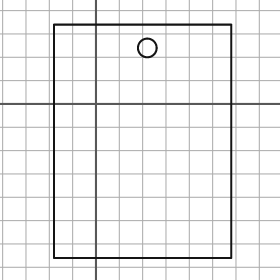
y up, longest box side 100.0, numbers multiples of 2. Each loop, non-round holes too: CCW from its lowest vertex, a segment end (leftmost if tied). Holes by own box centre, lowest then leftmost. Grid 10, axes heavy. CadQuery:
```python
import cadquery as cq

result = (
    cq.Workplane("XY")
    .moveTo(-18.0, -66.0)
    .lineTo(58.0, -66.0)
    .lineTo(58.0, 34.0)
    .lineTo(-18.0, 34.0)
    .close()
    .moveTo(22.0, 24.0)
    .circle(4.0)
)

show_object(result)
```